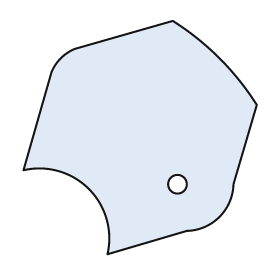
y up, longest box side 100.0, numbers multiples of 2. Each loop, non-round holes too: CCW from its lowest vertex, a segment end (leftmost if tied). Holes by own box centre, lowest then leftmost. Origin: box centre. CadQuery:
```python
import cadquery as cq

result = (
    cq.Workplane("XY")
    .moveTo(-14.0, -50.0)
    .lineTo(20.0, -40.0)
    .threePointArc((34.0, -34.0), (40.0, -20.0))
    .lineTo(50.0, 14.0)
    .threePointArc((34.0, 34.0), (14.0, 50.0))
    .lineTo(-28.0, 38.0)
    .threePointArc((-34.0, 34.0), (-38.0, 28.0))
    .lineTo(-50.0, -14.0)
    .threePointArc((-22.0, -22.0), (-14.0, -50.0))
    .close()
    .moveTo(16.0, -20.0)
    .circle(4.0)
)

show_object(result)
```